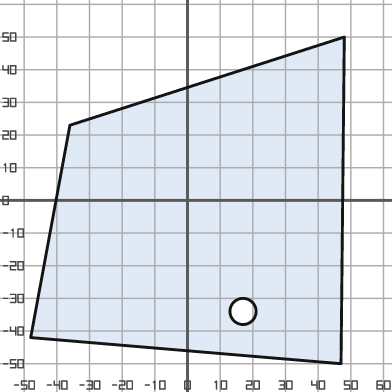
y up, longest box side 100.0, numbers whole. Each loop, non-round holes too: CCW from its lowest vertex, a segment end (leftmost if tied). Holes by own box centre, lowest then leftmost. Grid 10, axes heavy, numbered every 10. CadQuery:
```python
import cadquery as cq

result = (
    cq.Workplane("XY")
    .moveTo(47.0, -50.0)
    .lineTo(48.0, 50.0)
    .lineTo(-36.0, 23.0)
    .lineTo(-48.0, -42.0)
    .close()
    .moveTo(17.0, -34.0)
    .circle(4.0)
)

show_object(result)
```